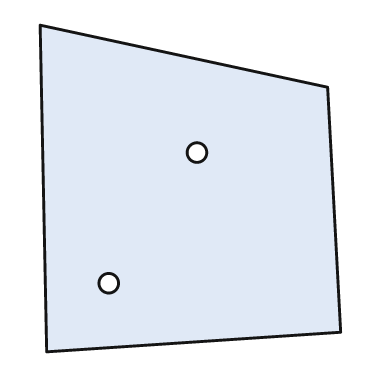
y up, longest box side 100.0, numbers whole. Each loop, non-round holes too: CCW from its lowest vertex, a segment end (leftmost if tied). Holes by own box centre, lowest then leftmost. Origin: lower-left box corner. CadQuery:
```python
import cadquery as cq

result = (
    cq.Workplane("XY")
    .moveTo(2.0, 0.0)
    .lineTo(92.0, 6.0)
    .lineTo(88.0, 81.0)
    .lineTo(0.0, 100.0)
    .close()
    .moveTo(21.0, 21.0)
    .circle(3.0)
    .moveTo(48.0, 61.0)
    .circle(3.0)
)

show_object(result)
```